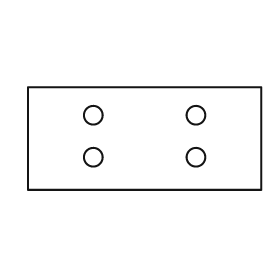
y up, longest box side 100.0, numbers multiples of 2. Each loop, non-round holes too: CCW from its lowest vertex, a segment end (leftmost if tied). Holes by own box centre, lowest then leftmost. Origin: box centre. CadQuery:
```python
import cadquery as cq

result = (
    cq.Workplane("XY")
    .moveTo(-50.0, -22.0)
    .lineTo(50.0, -22.0)
    .lineTo(50.0, 22.0)
    .lineTo(-50.0, 22.0)
    .close()
    .moveTo(-22.0, -8.0)
    .circle(4.0)
    .moveTo(22.0, -8.0)
    .circle(4.0)
    .moveTo(-22.0, 10.0)
    .circle(4.0)
    .moveTo(22.0, 10.0)
    .circle(4.0)
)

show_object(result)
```